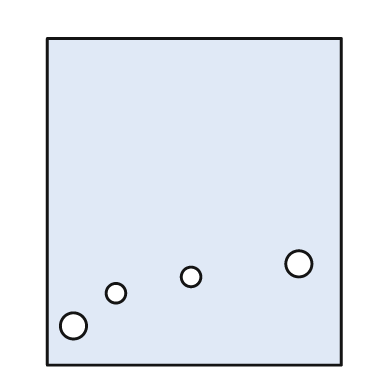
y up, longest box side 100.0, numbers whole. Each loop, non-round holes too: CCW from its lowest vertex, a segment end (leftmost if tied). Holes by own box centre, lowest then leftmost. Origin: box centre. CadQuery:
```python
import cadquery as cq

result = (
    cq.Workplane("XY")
    .moveTo(-45.0, -50.0)
    .lineTo(45.0, -50.0)
    .lineTo(45.0, 50.0)
    .lineTo(-45.0, 50.0)
    .close()
    .moveTo(-37.0, -38.0)
    .circle(4.0)
    .moveTo(-24.0, -28.0)
    .circle(3.0)
    .moveTo(-1.0, -23.0)
    .circle(3.0)
    .moveTo(32.0, -19.0)
    .circle(4.0)
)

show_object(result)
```